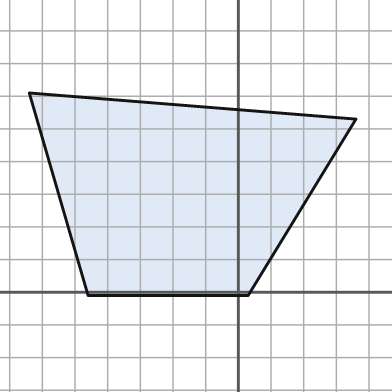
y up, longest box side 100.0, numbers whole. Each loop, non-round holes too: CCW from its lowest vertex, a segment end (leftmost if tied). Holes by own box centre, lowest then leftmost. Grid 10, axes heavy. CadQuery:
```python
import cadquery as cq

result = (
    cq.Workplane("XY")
    .moveTo(-46.0, -1.0)
    .lineTo(3.0, -1.0)
    .lineTo(36.0, 53.0)
    .lineTo(-64.0, 61.0)
    .close()
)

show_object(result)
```